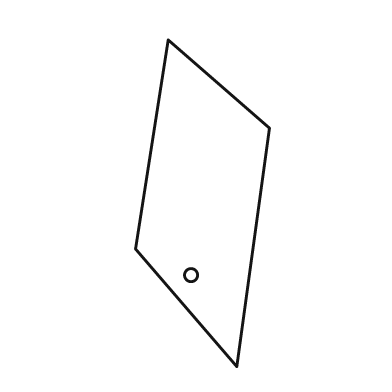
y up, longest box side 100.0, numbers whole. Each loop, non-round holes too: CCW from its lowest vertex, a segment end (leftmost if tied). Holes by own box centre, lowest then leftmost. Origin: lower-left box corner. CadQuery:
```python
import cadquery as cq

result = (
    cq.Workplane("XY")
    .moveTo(31.0, 0.0)
    .lineTo(41.0, 73.0)
    .lineTo(10.0, 100.0)
    .lineTo(0.0, 36.0)
    .close()
    .moveTo(17.0, 28.0)
    .circle(2.0)
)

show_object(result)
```